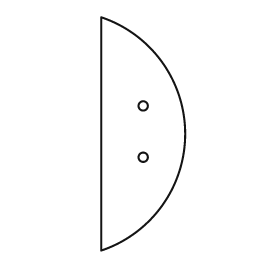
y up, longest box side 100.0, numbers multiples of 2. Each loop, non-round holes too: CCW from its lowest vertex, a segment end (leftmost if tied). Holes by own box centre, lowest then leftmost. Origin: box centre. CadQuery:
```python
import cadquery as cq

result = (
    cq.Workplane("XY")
    .moveTo(-18.0, -50.0)
    .threePointArc((18.0, 0.0), (-18.0, 50.0))
    .close()
    .moveTo(0.0, -10.0)
    .circle(2.0)
    .moveTo(0.0, 12.0)
    .circle(2.0)
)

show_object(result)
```